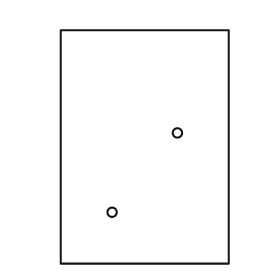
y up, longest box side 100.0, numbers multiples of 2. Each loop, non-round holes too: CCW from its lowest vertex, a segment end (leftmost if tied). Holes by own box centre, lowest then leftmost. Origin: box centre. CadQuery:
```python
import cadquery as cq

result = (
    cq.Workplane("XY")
    .moveTo(-36.0, -50.0)
    .lineTo(36.0, -50.0)
    .lineTo(36.0, 50.0)
    .lineTo(-36.0, 50.0)
    .close()
    .moveTo(-14.0, -28.0)
    .circle(2.0)
    .moveTo(14.0, 6.0)
    .circle(2.0)
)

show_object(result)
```